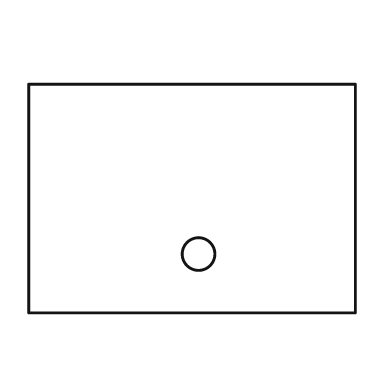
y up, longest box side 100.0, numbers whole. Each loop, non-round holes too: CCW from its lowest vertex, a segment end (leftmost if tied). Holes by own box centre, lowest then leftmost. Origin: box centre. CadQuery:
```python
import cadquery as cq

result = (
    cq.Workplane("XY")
    .moveTo(-50.0, -35.0)
    .lineTo(50.0, -35.0)
    .lineTo(50.0, 35.0)
    .lineTo(-50.0, 35.0)
    .close()
    .moveTo(2.0, -17.0)
    .circle(5.0)
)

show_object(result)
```